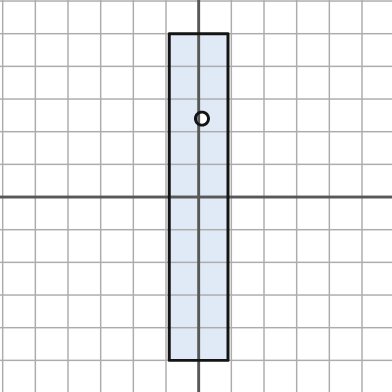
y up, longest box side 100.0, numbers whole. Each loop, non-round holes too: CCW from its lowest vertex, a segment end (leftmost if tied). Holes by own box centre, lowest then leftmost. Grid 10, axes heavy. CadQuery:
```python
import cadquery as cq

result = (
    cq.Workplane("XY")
    .moveTo(-9.0, -50.0)
    .lineTo(9.0, -50.0)
    .lineTo(9.0, 50.0)
    .lineTo(-9.0, 50.0)
    .close()
    .moveTo(1.0, 24.0)
    .circle(2.0)
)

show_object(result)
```